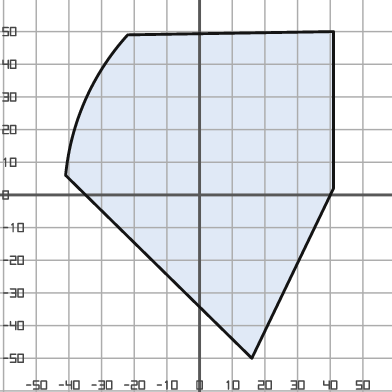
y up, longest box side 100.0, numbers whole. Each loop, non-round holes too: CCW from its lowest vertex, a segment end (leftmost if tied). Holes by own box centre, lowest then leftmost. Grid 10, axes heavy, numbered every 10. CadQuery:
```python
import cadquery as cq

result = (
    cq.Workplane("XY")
    .moveTo(16.0, -50.0)
    .lineTo(41.0, 2.0)
    .lineTo(41.0, 50.0)
    .lineTo(-22.0, 49.0)
    .threePointArc((-35.0, 29.0), (-41.0, 6.0))
    .close()
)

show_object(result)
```